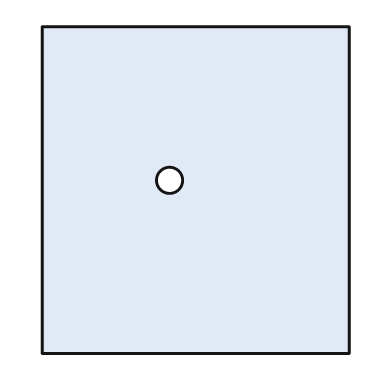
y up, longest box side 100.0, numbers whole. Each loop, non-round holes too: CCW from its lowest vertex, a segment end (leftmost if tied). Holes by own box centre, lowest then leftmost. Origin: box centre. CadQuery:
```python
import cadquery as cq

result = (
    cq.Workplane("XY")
    .moveTo(-47.0, -50.0)
    .lineTo(47.0, -50.0)
    .lineTo(47.0, 50.0)
    .lineTo(-47.0, 50.0)
    .close()
    .moveTo(-8.0, 3.0)
    .circle(4.0)
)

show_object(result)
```